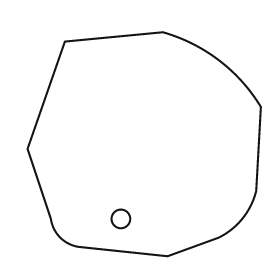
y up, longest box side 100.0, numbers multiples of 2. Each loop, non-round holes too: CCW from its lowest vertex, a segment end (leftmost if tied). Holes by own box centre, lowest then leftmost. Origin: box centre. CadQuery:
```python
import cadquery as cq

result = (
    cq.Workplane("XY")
    .moveTo(10.0, -48.0)
    .lineTo(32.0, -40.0)
    .threePointArc((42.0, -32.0), (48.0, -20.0))
    .lineTo(50.0, 16.0)
    .threePointArc((32.0, 36.0), (8.0, 48.0))
    .lineTo(-34.0, 44.0)
    .lineTo(-50.0, -2.0)
    .lineTo(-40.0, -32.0)
    .threePointArc((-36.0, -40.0), (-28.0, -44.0))
    .close()
    .moveTo(-10.0, -32.0)
    .circle(4.0)
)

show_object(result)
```